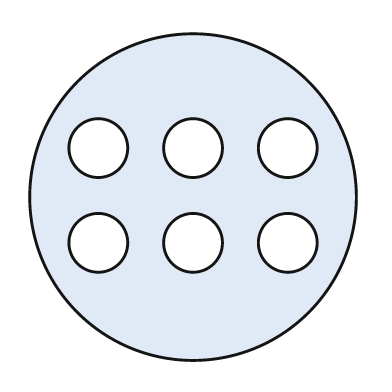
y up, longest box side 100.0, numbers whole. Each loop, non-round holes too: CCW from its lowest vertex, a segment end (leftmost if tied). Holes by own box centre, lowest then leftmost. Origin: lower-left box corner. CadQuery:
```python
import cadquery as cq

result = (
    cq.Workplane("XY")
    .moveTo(50.0, 50.0)
    .circle(50.0)
    .moveTo(21.0, 36.0)
    .circle(9.0)
    .moveTo(50.0, 36.0)
    .circle(9.0)
    .moveTo(79.0, 36.0)
    .circle(9.0)
    .moveTo(21.0, 65.0)
    .circle(9.0)
    .moveTo(50.0, 65.0)
    .circle(9.0)
    .moveTo(79.0, 65.0)
    .circle(9.0)
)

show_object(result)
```